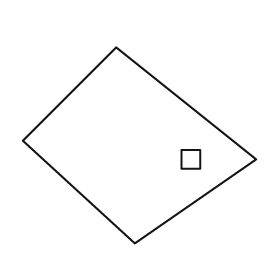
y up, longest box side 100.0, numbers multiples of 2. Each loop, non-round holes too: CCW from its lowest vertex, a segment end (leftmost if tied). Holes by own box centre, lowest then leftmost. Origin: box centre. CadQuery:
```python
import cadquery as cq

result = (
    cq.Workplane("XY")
    .moveTo(-2.0, -42.0)
    .lineTo(50.0, -6.0)
    .lineTo(-10.0, 42.0)
    .lineTo(-50.0, 2.0)
    .close()
    .moveTo(18.0, -10.0)
    .lineTo(26.0, -10.0)
    .lineTo(26.0, -2.0)
    .lineTo(18.0, -2.0)
    .close()
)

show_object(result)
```